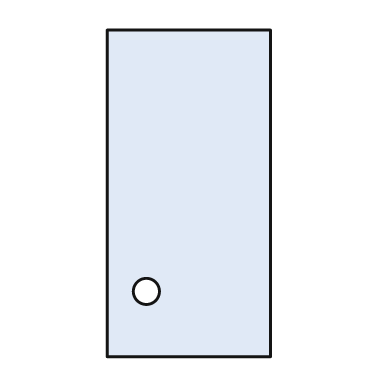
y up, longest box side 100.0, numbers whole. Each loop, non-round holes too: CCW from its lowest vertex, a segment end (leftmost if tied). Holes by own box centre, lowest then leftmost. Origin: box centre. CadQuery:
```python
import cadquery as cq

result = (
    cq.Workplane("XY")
    .moveTo(-25.0, -50.0)
    .lineTo(25.0, -50.0)
    .lineTo(25.0, 50.0)
    .lineTo(-25.0, 50.0)
    .close()
    .moveTo(-13.0, -30.0)
    .circle(4.0)
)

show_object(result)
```